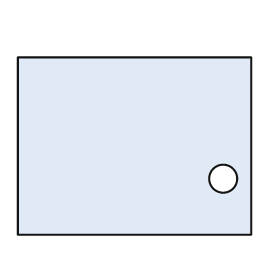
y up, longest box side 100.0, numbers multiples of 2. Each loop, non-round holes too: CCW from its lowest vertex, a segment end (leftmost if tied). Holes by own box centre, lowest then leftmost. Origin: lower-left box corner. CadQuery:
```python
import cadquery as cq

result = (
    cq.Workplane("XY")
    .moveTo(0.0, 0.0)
    .lineTo(100.0, 0.0)
    .lineTo(100.0, 76.0)
    .lineTo(0.0, 76.0)
    .close()
    .moveTo(88.0, 24.0)
    .circle(6.0)
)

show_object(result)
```